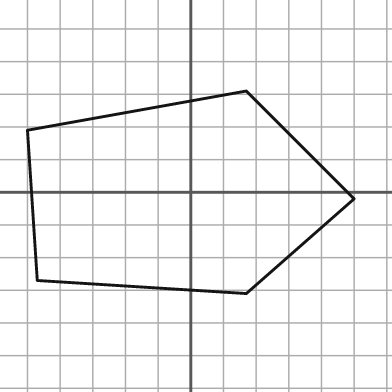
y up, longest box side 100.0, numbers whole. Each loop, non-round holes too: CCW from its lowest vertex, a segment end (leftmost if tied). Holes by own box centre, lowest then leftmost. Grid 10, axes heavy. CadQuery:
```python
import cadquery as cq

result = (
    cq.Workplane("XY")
    .moveTo(17.0, -31.0)
    .lineTo(50.0, -2.0)
    .lineTo(17.0, 31.0)
    .lineTo(-50.0, 19.0)
    .lineTo(-47.0, -27.0)
    .close()
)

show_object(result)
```